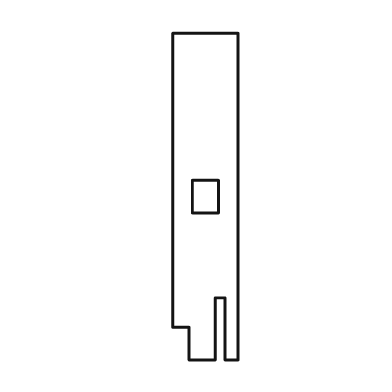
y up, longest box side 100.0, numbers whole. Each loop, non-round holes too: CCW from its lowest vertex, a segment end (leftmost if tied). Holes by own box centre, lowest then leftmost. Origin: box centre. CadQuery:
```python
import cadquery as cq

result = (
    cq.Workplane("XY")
    .moveTo(-5.0, -50.0)
    .lineTo(3.0, -50.0)
    .lineTo(3.0, -31.0)
    .lineTo(6.0, -31.0)
    .lineTo(6.0, -50.0)
    .lineTo(10.0, -50.0)
    .lineTo(10.0, 50.0)
    .lineTo(-10.0, 50.0)
    .lineTo(-10.0, -40.0)
    .lineTo(-5.0, -40.0)
    .close()
    .moveTo(-4.0, -5.0)
    .lineTo(4.0, -5.0)
    .lineTo(4.0, 5.0)
    .lineTo(-4.0, 5.0)
    .close()
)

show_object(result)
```